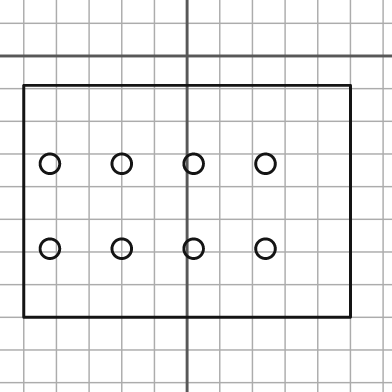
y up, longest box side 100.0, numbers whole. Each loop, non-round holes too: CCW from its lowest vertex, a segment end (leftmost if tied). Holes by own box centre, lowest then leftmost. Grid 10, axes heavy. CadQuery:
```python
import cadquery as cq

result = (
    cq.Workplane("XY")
    .moveTo(-50.0, -80.0)
    .lineTo(50.0, -80.0)
    .lineTo(50.0, -9.0)
    .lineTo(-50.0, -9.0)
    .close()
    .moveTo(-42.0, -59.0)
    .circle(3.0)
    .moveTo(-20.0, -59.0)
    .circle(3.0)
    .moveTo(2.0, -59.0)
    .circle(3.0)
    .moveTo(24.0, -59.0)
    .circle(3.0)
    .moveTo(-42.0, -33.0)
    .circle(3.0)
    .moveTo(-20.0, -33.0)
    .circle(3.0)
    .moveTo(2.0, -33.0)
    .circle(3.0)
    .moveTo(24.0, -33.0)
    .circle(3.0)
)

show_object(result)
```